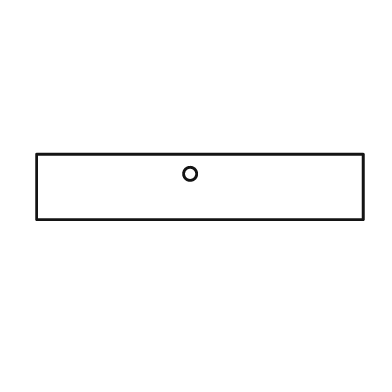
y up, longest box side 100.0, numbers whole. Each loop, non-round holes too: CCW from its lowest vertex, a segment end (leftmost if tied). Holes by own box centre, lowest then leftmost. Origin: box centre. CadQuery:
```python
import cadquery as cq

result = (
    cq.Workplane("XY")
    .moveTo(-50.0, -10.0)
    .lineTo(50.0, -10.0)
    .lineTo(50.0, 10.0)
    .lineTo(-50.0, 10.0)
    .close()
    .moveTo(-3.0, 4.0)
    .circle(2.0)
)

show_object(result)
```